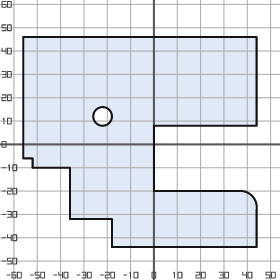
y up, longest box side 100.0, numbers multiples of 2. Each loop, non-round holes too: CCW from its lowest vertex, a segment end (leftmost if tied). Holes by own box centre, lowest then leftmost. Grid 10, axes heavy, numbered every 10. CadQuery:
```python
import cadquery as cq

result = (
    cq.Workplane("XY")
    .moveTo(-18.0, -44.0)
    .lineTo(44.0, -44.0)
    .lineTo(44.0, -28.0)
    .threePointArc((42.0, -22.0), (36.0, -20.0))
    .lineTo(0.0, -20.0)
    .lineTo(0.0, 8.0)
    .lineTo(44.0, 8.0)
    .lineTo(44.0, 46.0)
    .lineTo(-56.0, 46.0)
    .lineTo(-56.0, -6.0)
    .lineTo(-52.0, -6.0)
    .lineTo(-52.0, -10.0)
    .lineTo(-36.0, -10.0)
    .lineTo(-36.0, -32.0)
    .lineTo(-18.0, -32.0)
    .close()
    .moveTo(-22.0, 12.0)
    .circle(4.0)
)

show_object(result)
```